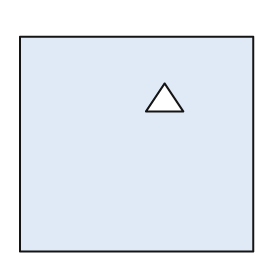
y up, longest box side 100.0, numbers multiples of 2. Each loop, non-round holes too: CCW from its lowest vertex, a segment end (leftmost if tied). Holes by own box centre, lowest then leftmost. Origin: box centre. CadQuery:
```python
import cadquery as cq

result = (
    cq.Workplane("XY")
    .moveTo(-50.0, -46.0)
    .lineTo(50.0, -46.0)
    .lineTo(50.0, 46.0)
    .lineTo(-50.0, 46.0)
    .close()
    .moveTo(4.0, 14.0)
    .lineTo(20.0, 14.0)
    .lineTo(12.0, 26.0)
    .close()
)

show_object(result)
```